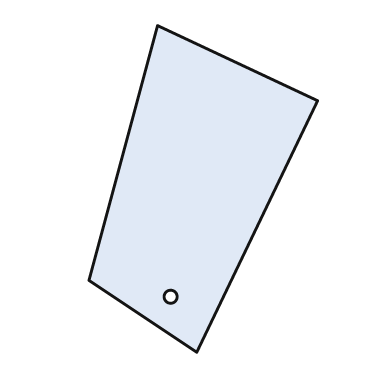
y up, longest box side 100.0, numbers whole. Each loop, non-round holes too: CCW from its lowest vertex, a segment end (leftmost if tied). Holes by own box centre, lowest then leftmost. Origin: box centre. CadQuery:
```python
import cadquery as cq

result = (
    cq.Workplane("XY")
    .moveTo(-2.0, -50.0)
    .lineTo(35.0, 27.0)
    .lineTo(-14.0, 50.0)
    .lineTo(-35.0, -28.0)
    .close()
    .moveTo(-10.0, -33.0)
    .circle(2.0)
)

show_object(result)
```